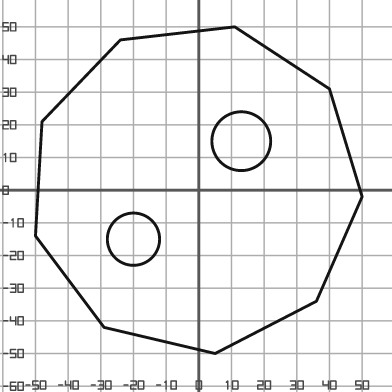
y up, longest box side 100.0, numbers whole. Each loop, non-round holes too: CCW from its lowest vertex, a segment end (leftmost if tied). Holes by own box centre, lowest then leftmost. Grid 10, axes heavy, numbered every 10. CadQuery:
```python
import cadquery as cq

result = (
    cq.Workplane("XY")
    .moveTo(5.0, -50.0)
    .lineTo(36.0, -34.0)
    .lineTo(50.0, -2.0)
    .lineTo(40.0, 31.0)
    .lineTo(11.0, 50.0)
    .lineTo(-24.0, 46.0)
    .lineTo(-48.0, 21.0)
    .lineTo(-50.0, -14.0)
    .lineTo(-29.0, -42.0)
    .close()
    .moveTo(-20.0, -15.0)
    .circle(8.0)
    .moveTo(13.0, 15.0)
    .circle(9.0)
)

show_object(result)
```